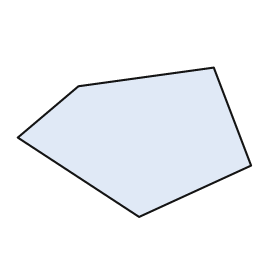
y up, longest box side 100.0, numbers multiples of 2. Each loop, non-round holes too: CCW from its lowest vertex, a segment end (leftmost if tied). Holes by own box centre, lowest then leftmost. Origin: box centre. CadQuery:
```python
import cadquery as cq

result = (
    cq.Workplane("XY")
    .moveTo(2.0, -32.0)
    .lineTo(50.0, -10.0)
    .lineTo(34.0, 32.0)
    .lineTo(-24.0, 24.0)
    .lineTo(-50.0, 2.0)
    .close()
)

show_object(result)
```